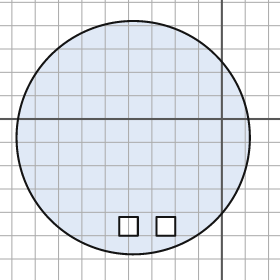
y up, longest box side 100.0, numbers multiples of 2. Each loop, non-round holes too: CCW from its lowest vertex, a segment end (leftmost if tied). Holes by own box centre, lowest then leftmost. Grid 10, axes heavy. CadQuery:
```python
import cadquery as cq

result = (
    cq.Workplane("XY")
    .moveTo(-38.0, -8.0)
    .circle(50.0)
    .moveTo(-44.0, -50.0)
    .lineTo(-36.0, -50.0)
    .lineTo(-36.0, -42.0)
    .lineTo(-44.0, -42.0)
    .close()
    .moveTo(-28.0, -50.0)
    .lineTo(-20.0, -50.0)
    .lineTo(-20.0, -42.0)
    .lineTo(-28.0, -42.0)
    .close()
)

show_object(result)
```